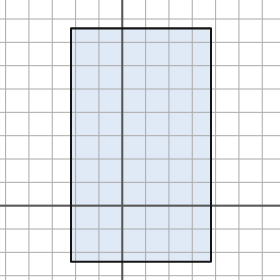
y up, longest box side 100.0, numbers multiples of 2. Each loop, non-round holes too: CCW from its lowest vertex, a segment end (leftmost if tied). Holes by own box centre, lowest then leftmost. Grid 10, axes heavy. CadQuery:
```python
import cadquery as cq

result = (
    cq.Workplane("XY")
    .moveTo(-22.0, -24.0)
    .lineTo(38.0, -24.0)
    .lineTo(38.0, 76.0)
    .lineTo(-22.0, 76.0)
    .close()
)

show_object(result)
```